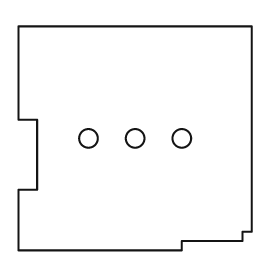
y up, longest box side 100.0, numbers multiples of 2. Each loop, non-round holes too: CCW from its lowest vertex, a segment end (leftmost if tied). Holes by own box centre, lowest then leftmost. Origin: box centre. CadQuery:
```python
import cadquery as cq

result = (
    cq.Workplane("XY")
    .moveTo(-50.0, -48.0)
    .lineTo(20.0, -48.0)
    .lineTo(20.0, -44.0)
    .lineTo(46.0, -44.0)
    .lineTo(46.0, -40.0)
    .lineTo(50.0, -40.0)
    .lineTo(50.0, 48.0)
    .lineTo(-50.0, 48.0)
    .lineTo(-50.0, 8.0)
    .lineTo(-42.0, 8.0)
    .lineTo(-42.0, -22.0)
    .lineTo(-50.0, -22.0)
    .close()
    .moveTo(-20.0, 0.0)
    .circle(4.0)
    .moveTo(0.0, 0.0)
    .circle(4.0)
    .moveTo(20.0, 0.0)
    .circle(4.0)
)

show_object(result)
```